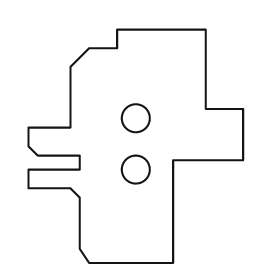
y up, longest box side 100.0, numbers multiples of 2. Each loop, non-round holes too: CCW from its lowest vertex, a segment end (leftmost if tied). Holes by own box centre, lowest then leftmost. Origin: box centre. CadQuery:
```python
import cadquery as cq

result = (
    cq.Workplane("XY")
    .moveTo(-20.0, -50.0)
    .lineTo(16.0, -50.0)
    .lineTo(16.0, -6.0)
    .lineTo(46.0, -6.0)
    .lineTo(46.0, 16.0)
    .lineTo(30.0, 16.0)
    .lineTo(30.0, 50.0)
    .lineTo(-8.0, 50.0)
    .lineTo(-8.0, 42.0)
    .lineTo(-20.0, 42.0)
    .lineTo(-28.0, 34.0)
    .lineTo(-28.0, 8.0)
    .lineTo(-46.0, 8.0)
    .lineTo(-46.0, 0.0)
    .lineTo(-42.0, -4.0)
    .lineTo(-24.0, -4.0)
    .lineTo(-24.0, -10.0)
    .lineTo(-46.0, -10.0)
    .lineTo(-46.0, -18.0)
    .lineTo(-28.0, -18.0)
    .lineTo(-24.0, -22.0)
    .lineTo(-24.0, -44.0)
    .close()
    .moveTo(0.0, -10.0)
    .circle(6.0)
    .moveTo(0.0, 12.0)
    .circle(6.0)
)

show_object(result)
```